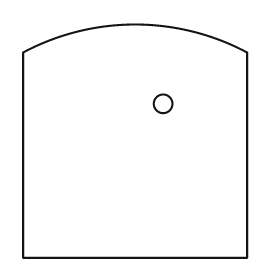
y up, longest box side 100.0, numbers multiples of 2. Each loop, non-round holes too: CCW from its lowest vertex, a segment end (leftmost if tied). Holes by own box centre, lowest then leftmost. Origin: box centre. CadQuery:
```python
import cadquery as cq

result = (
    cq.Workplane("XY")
    .moveTo(-48.0, -50.0)
    .lineTo(48.0, -50.0)
    .lineTo(48.0, 38.0)
    .threePointArc((0.0, 50.0), (-48.0, 38.0))
    .close()
    .moveTo(12.0, 16.0)
    .circle(4.0)
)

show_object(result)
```